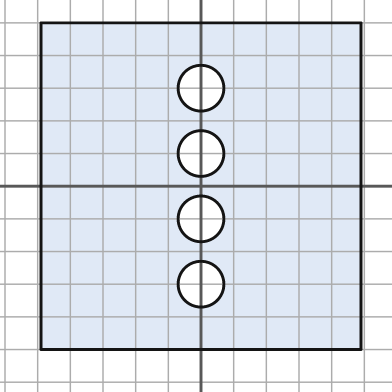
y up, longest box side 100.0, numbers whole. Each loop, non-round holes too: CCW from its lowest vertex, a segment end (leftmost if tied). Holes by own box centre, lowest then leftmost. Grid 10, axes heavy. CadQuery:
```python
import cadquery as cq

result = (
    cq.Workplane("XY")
    .moveTo(-49.0, -50.0)
    .lineTo(49.0, -50.0)
    .lineTo(49.0, 50.0)
    .lineTo(-49.0, 50.0)
    .close()
    .moveTo(0.0, -30.0)
    .circle(7.0)
    .moveTo(0.0, -10.0)
    .circle(7.0)
    .moveTo(0.0, 10.0)
    .circle(7.0)
    .moveTo(0.0, 30.0)
    .circle(7.0)
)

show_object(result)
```